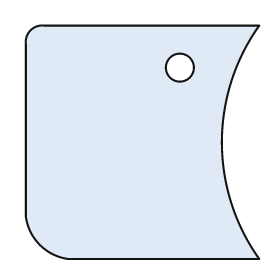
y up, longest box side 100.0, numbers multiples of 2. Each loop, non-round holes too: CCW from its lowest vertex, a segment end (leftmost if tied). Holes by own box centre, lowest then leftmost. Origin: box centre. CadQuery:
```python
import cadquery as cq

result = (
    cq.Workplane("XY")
    .moveTo(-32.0, -50.0)
    .lineTo(50.0, -50.0)
    .threePointArc((34.0, 0.0), (50.0, 50.0))
    .lineTo(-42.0, 50.0)
    .threePointArc((-48.0, 48.0), (-50.0, 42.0))
    .lineTo(-50.0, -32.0)
    .threePointArc((-44.0, -44.0), (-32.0, -50.0))
    .close()
    .moveTo(16.0, 32.0)
    .circle(6.0)
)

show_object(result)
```